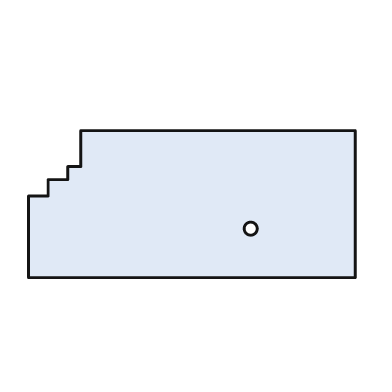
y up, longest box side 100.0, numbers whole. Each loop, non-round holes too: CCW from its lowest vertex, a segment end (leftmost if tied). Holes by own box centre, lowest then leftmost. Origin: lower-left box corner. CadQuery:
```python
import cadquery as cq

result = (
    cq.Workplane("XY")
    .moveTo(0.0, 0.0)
    .lineTo(100.0, 0.0)
    .lineTo(100.0, 45.0)
    .lineTo(16.0, 45.0)
    .lineTo(16.0, 34.0)
    .lineTo(12.0, 34.0)
    .lineTo(12.0, 30.0)
    .lineTo(6.0, 30.0)
    .lineTo(6.0, 25.0)
    .lineTo(0.0, 25.0)
    .close()
    .moveTo(68.0, 15.0)
    .circle(2.0)
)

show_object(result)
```